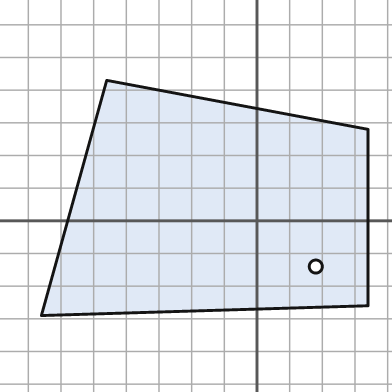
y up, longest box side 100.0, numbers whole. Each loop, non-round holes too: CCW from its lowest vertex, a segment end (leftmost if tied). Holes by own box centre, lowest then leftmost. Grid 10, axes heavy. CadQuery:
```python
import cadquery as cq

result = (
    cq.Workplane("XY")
    .moveTo(-66.0, -29.0)
    .lineTo(34.0, -26.0)
    .lineTo(34.0, 28.0)
    .lineTo(-46.0, 43.0)
    .close()
    .moveTo(18.0, -14.0)
    .circle(2.0)
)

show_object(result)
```